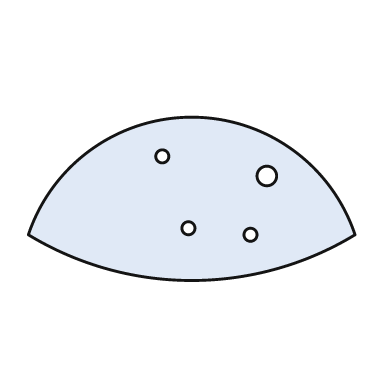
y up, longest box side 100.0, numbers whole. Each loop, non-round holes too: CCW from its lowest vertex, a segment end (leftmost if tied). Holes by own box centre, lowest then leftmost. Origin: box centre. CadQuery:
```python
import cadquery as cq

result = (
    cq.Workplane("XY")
    .moveTo(-50.0, -11.0)
    .threePointArc((0.0, -25.0), (50.0, -11.0))
    .threePointArc((0.0, 25.0), (-50.0, -11.0))
    .close()
    .moveTo(18.0, -11.0)
    .circle(2.0)
    .moveTo(-1.0, -9.0)
    .circle(2.0)
    .moveTo(23.0, 7.0)
    .circle(3.0)
    .moveTo(-9.0, 13.0)
    .circle(2.0)
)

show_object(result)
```